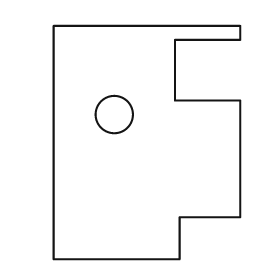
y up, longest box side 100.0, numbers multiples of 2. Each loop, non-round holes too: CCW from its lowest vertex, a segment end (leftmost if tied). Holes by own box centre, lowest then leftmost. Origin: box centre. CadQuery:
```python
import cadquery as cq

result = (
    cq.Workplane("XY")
    .moveTo(-40.0, -50.0)
    .lineTo(14.0, -50.0)
    .lineTo(14.0, -32.0)
    .lineTo(40.0, -32.0)
    .lineTo(40.0, 18.0)
    .lineTo(12.0, 18.0)
    .lineTo(12.0, 44.0)
    .lineTo(40.0, 44.0)
    .lineTo(40.0, 50.0)
    .lineTo(-40.0, 50.0)
    .close()
    .moveTo(-14.0, 12.0)
    .circle(8.0)
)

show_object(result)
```